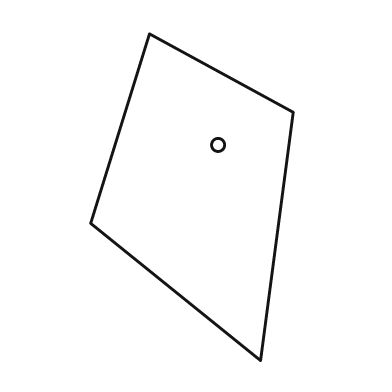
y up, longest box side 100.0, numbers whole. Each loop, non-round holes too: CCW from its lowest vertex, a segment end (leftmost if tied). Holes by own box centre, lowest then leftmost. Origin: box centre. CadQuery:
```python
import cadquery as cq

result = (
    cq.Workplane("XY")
    .moveTo(21.0, -50.0)
    .lineTo(31.0, 26.0)
    .lineTo(-13.0, 50.0)
    .lineTo(-31.0, -8.0)
    .close()
    .moveTo(8.0, 16.0)
    .circle(2.0)
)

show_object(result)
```